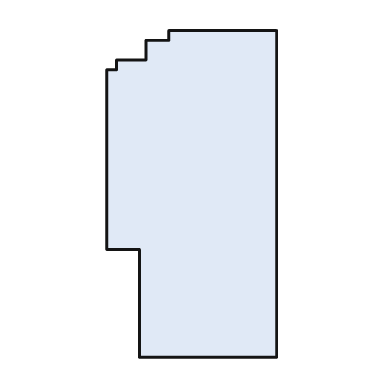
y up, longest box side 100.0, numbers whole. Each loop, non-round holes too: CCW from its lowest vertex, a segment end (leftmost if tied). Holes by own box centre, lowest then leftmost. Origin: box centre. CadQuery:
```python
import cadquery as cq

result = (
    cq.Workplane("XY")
    .moveTo(-16.0, -50.0)
    .lineTo(26.0, -50.0)
    .lineTo(26.0, 50.0)
    .lineTo(-7.0, 50.0)
    .lineTo(-7.0, 47.0)
    .lineTo(-14.0, 47.0)
    .lineTo(-14.0, 41.0)
    .lineTo(-23.0, 41.0)
    .lineTo(-23.0, 38.0)
    .lineTo(-26.0, 38.0)
    .lineTo(-26.0, -17.0)
    .lineTo(-16.0, -17.0)
    .close()
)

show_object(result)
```